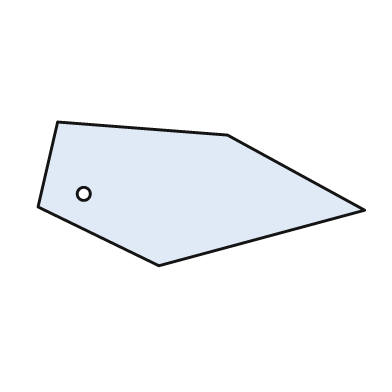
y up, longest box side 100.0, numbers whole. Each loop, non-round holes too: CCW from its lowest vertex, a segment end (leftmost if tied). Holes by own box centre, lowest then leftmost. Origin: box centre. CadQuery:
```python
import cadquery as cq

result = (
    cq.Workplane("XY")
    .moveTo(-13.0, -22.0)
    .lineTo(50.0, -5.0)
    .lineTo(8.0, 18.0)
    .lineTo(-44.0, 22.0)
    .lineTo(-50.0, -4.0)
    .close()
    .moveTo(-36.0, 0.0)
    .circle(2.0)
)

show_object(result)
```